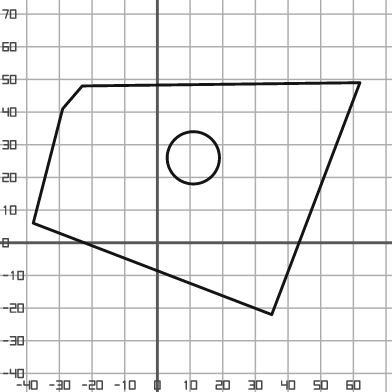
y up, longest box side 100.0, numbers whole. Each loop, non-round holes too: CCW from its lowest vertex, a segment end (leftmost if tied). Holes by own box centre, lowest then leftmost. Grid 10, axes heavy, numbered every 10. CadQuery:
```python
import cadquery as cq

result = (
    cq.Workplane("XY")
    .moveTo(35.0, -22.0)
    .lineTo(62.0, 49.0)
    .lineTo(-23.0, 48.0)
    .lineTo(-29.0, 41.0)
    .lineTo(-38.0, 6.0)
    .close()
    .moveTo(11.0, 26.0)
    .circle(8.0)
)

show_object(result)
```